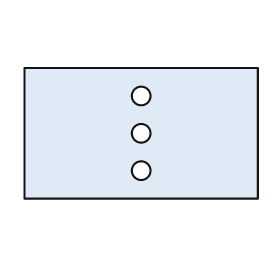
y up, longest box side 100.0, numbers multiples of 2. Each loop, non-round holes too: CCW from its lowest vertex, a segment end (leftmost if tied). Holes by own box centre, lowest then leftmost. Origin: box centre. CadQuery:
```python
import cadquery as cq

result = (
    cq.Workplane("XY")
    .moveTo(-50.0, -28.0)
    .lineTo(50.0, -28.0)
    .lineTo(50.0, 28.0)
    .lineTo(-50.0, 28.0)
    .close()
    .moveTo(0.0, -16.0)
    .circle(4.0)
    .moveTo(0.0, 0.0)
    .circle(4.0)
    .moveTo(0.0, 16.0)
    .circle(4.0)
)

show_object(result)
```